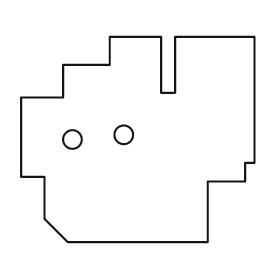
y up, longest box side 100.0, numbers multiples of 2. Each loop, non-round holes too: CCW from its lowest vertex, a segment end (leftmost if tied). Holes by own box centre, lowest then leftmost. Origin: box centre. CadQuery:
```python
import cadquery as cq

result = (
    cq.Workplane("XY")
    .moveTo(-30.0, -44.0)
    .lineTo(30.0, -44.0)
    .lineTo(30.0, -18.0)
    .lineTo(46.0, -18.0)
    .lineTo(46.0, -10.0)
    .lineTo(50.0, -10.0)
    .lineTo(50.0, 44.0)
    .lineTo(16.0, 44.0)
    .lineTo(16.0, 20.0)
    .lineTo(10.0, 20.0)
    .lineTo(10.0, 44.0)
    .lineTo(-12.0, 44.0)
    .lineTo(-12.0, 32.0)
    .lineTo(-32.0, 32.0)
    .lineTo(-32.0, 18.0)
    .lineTo(-50.0, 18.0)
    .lineTo(-50.0, -16.0)
    .lineTo(-40.0, -16.0)
    .lineTo(-40.0, -34.0)
    .close()
    .moveTo(-28.0, 0.0)
    .circle(4.0)
    .moveTo(-6.0, 2.0)
    .circle(4.0)
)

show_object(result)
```